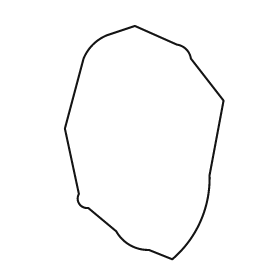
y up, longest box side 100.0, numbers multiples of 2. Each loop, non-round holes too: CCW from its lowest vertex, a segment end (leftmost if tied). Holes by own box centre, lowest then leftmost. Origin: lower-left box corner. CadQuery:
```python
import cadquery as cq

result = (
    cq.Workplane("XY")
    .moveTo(46.0, 0.0)
    .threePointArc((58.0, 16.0), (62.0, 36.0))
    .lineTo(68.0, 68.0)
    .lineTo(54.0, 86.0)
    .threePointArc((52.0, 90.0), (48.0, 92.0))
    .lineTo(30.0, 100.0)
    .lineTo(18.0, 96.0)
    .threePointArc((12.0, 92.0), (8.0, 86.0))
    .lineTo(0.0, 56.0)
    .lineTo(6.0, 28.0)
    .threePointArc((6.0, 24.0), (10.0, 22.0))
    .lineTo(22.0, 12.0)
    .threePointArc((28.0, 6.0), (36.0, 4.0))
    .close()
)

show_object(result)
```